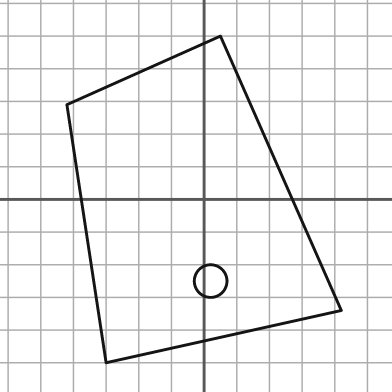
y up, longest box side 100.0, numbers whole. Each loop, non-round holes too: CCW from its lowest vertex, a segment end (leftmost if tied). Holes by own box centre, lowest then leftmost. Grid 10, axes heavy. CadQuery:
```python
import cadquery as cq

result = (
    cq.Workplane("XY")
    .moveTo(-30.0, -50.0)
    .lineTo(42.0, -34.0)
    .lineTo(5.0, 50.0)
    .lineTo(-42.0, 29.0)
    .close()
    .moveTo(2.0, -25.0)
    .circle(5.0)
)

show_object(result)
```